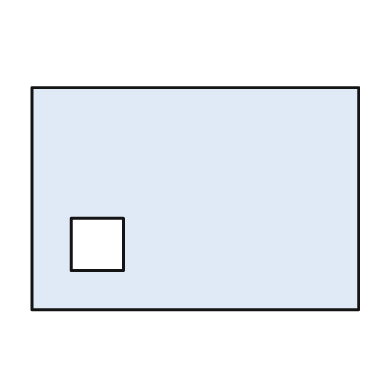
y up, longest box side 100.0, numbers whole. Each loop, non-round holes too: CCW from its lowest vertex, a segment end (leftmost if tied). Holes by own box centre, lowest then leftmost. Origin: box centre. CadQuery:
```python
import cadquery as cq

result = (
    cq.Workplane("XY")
    .moveTo(-50.0, -34.0)
    .lineTo(50.0, -34.0)
    .lineTo(50.0, 34.0)
    .lineTo(-50.0, 34.0)
    .close()
    .moveTo(-38.0, -22.0)
    .lineTo(-22.0, -22.0)
    .lineTo(-22.0, -6.0)
    .lineTo(-38.0, -6.0)
    .close()
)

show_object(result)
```